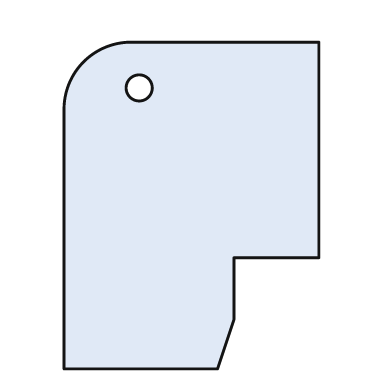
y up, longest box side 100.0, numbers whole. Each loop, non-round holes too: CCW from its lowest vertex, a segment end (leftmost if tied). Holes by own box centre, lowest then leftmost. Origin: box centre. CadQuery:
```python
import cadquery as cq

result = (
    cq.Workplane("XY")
    .moveTo(-39.0, -50.0)
    .lineTo(8.0, -50.0)
    .lineTo(13.0, -35.0)
    .lineTo(13.0, -16.0)
    .lineTo(39.0, -16.0)
    .lineTo(39.0, 50.0)
    .lineTo(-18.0, 50.0)
    .threePointArc((-33.0, 44.0), (-39.0, 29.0))
    .close()
    .moveTo(-16.0, 36.0)
    .circle(4.0)
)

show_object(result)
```